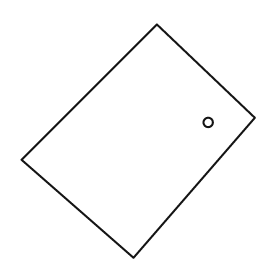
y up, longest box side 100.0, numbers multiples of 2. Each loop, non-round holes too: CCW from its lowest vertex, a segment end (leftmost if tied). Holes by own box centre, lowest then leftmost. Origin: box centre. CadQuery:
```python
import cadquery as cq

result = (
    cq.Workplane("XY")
    .moveTo(-2.0, -50.0)
    .lineTo(50.0, 10.0)
    .lineTo(8.0, 50.0)
    .lineTo(-50.0, -8.0)
    .close()
    .moveTo(30.0, 8.0)
    .circle(2.0)
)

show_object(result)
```